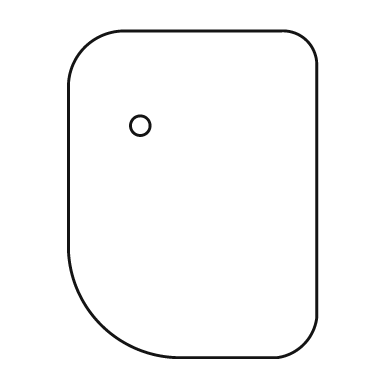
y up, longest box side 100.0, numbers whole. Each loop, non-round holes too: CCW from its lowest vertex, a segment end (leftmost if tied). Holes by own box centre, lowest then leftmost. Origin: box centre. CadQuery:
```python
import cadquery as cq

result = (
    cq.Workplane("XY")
    .moveTo(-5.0, -50.0)
    .lineTo(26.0, -50.0)
    .threePointArc((34.0, -46.0), (38.0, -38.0))
    .lineTo(38.0, 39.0)
    .threePointArc((35.0, 47.0), (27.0, 50.0))
    .lineTo(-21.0, 50.0)
    .threePointArc((-33.0, 45.0), (-38.0, 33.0))
    .lineTo(-38.0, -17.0)
    .threePointArc((-28.0, -40.0), (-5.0, -50.0))
    .close()
    .moveTo(-16.0, 21.0)
    .circle(3.0)
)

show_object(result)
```